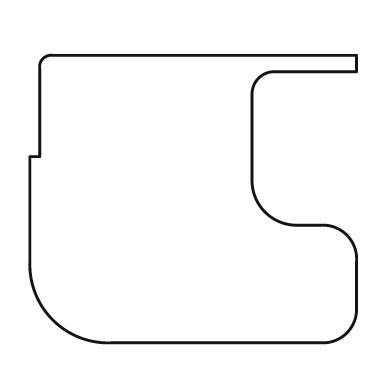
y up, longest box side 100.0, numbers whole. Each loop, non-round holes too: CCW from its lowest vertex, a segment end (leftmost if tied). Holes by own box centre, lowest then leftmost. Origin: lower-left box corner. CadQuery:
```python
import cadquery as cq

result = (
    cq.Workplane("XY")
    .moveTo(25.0, 0.0)
    .lineTo(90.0, 0.0)
    .threePointArc((97.0, 3.0), (100.0, 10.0))
    .lineTo(100.0, 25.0)
    .threePointArc((97.0, 33.0), (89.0, 36.0))
    .lineTo(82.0, 36.0)
    .threePointArc((72.0, 40.0), (68.0, 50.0))
    .lineTo(68.0, 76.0)
    .threePointArc((70.0, 81.0), (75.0, 83.0))
    .lineTo(100.0, 83.0)
    .lineTo(100.0, 88.0)
    .lineTo(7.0, 88.0)
    .threePointArc((4.0, 87.0), (3.0, 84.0))
    .lineTo(3.0, 57.0)
    .lineTo(0.0, 57.0)
    .lineTo(0.0, 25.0)
    .threePointArc((7.0, 7.0), (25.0, 0.0))
    .close()
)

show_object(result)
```